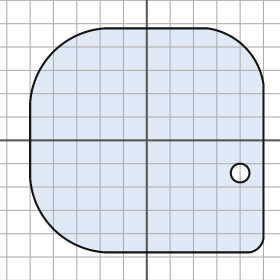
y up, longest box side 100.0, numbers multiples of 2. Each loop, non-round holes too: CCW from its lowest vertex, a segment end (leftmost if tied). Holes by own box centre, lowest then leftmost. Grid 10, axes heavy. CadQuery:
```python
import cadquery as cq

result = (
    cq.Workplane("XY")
    .moveTo(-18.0, -48.0)
    .lineTo(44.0, -48.0)
    .threePointArc((48.0, -46.0), (50.0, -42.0))
    .lineTo(50.0, 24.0)
    .threePointArc((42.0, 40.0), (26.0, 48.0))
    .lineTo(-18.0, 48.0)
    .threePointArc((-40.0, 38.0), (-50.0, 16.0))
    .lineTo(-50.0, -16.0)
    .threePointArc((-40.0, -38.0), (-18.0, -48.0))
    .close()
    .moveTo(40.0, -14.0)
    .circle(4.0)
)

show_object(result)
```